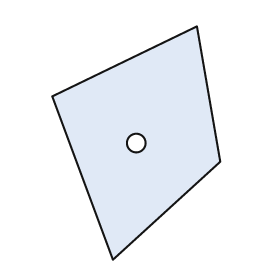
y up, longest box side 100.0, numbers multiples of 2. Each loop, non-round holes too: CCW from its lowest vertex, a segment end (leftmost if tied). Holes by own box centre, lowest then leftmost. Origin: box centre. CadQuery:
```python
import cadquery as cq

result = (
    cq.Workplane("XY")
    .moveTo(-10.0, -50.0)
    .lineTo(36.0, -8.0)
    .lineTo(26.0, 50.0)
    .lineTo(-36.0, 20.0)
    .close()
    .moveTo(0.0, 0.0)
    .circle(4.0)
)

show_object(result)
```